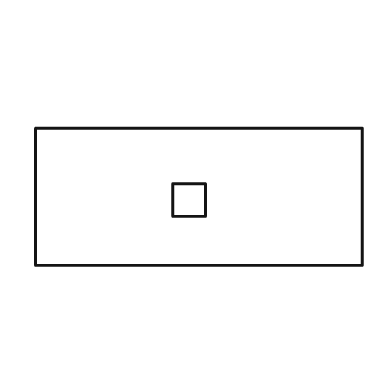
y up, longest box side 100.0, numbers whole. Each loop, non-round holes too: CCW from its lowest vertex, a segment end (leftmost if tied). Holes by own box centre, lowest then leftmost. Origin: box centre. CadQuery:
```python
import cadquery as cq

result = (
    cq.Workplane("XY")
    .moveTo(-50.0, -21.0)
    .lineTo(50.0, -21.0)
    .lineTo(50.0, 21.0)
    .lineTo(-50.0, 21.0)
    .close()
    .moveTo(-8.0, -6.0)
    .lineTo(2.0, -6.0)
    .lineTo(2.0, 4.0)
    .lineTo(-8.0, 4.0)
    .close()
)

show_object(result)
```